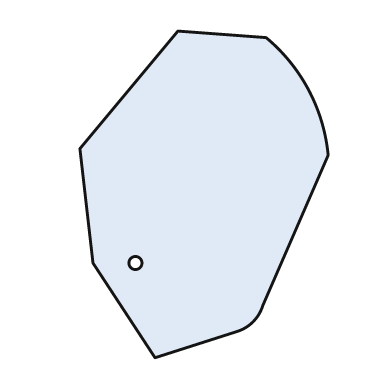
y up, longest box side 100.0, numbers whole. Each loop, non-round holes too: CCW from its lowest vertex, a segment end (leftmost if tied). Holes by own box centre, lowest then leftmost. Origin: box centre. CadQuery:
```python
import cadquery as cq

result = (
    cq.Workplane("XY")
    .moveTo(-15.0, -50.0)
    .lineTo(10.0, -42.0)
    .threePointArc((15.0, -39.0), (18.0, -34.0))
    .lineTo(38.0, 12.0)
    .threePointArc((32.0, 32.0), (19.0, 48.0))
    .lineTo(-8.0, 50.0)
    .lineTo(-38.0, 14.0)
    .lineTo(-34.0, -21.0)
    .close()
    .moveTo(-21.0, -21.0)
    .circle(2.0)
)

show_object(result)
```